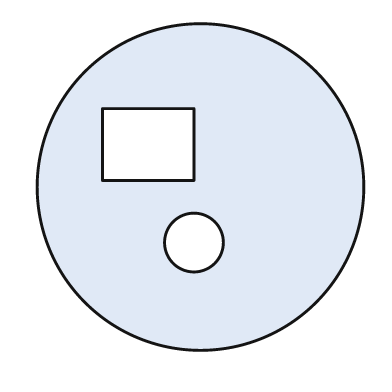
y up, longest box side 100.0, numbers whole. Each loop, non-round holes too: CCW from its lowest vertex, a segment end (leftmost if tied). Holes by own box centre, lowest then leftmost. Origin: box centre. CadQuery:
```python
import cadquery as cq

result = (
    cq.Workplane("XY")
    .moveTo(0.0, 0.0)
    .circle(50.0)
    .moveTo(-2.0, -17.0)
    .circle(9.0)
    .moveTo(-30.0, 2.0)
    .lineTo(-2.0, 2.0)
    .lineTo(-2.0, 24.0)
    .lineTo(-30.0, 24.0)
    .close()
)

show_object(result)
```